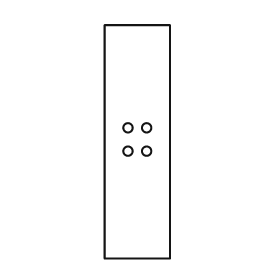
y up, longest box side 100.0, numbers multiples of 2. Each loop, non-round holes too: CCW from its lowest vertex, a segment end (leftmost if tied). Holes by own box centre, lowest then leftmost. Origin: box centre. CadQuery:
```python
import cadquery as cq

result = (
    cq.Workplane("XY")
    .moveTo(-14.0, -50.0)
    .lineTo(14.0, -50.0)
    .lineTo(14.0, 50.0)
    .lineTo(-14.0, 50.0)
    .close()
    .moveTo(-4.0, -4.0)
    .circle(2.0)
    .moveTo(4.0, -4.0)
    .circle(2.0)
    .moveTo(-4.0, 6.0)
    .circle(2.0)
    .moveTo(4.0, 6.0)
    .circle(2.0)
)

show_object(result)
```